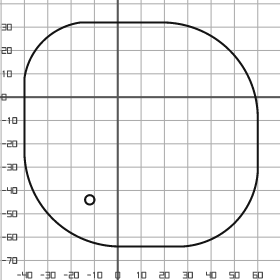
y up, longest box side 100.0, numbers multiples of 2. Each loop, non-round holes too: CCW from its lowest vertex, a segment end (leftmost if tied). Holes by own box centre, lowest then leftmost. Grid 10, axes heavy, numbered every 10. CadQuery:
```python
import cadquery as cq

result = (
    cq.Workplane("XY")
    .moveTo(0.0, -64.0)
    .lineTo(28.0, -64.0)
    .threePointArc((50.0, -54.0), (60.0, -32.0))
    .lineTo(60.0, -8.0)
    .threePointArc((48.0, 20.0), (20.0, 32.0))
    .lineTo(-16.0, 32.0)
    .threePointArc((-32.0, 24.0), (-40.0, 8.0))
    .lineTo(-40.0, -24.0)
    .threePointArc((-28.0, -52.0), (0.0, -64.0))
    .close()
    .moveTo(-12.0, -44.0)
    .circle(2.0)
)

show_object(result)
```